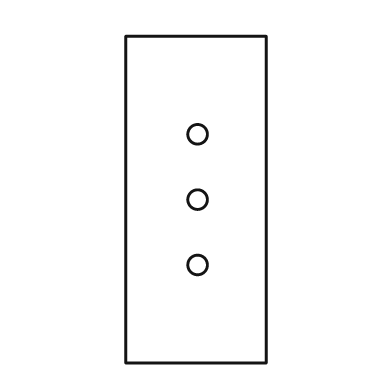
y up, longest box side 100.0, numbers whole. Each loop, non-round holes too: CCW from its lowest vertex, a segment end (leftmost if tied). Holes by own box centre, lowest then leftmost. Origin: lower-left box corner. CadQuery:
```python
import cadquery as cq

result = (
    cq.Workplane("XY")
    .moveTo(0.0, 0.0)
    .lineTo(43.0, 0.0)
    .lineTo(43.0, 100.0)
    .lineTo(0.0, 100.0)
    .close()
    .moveTo(22.0, 30.0)
    .circle(3.0)
    .moveTo(22.0, 50.0)
    .circle(3.0)
    .moveTo(22.0, 70.0)
    .circle(3.0)
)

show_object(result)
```